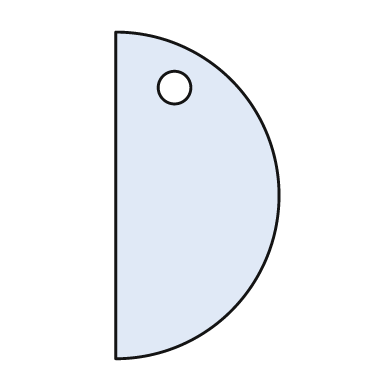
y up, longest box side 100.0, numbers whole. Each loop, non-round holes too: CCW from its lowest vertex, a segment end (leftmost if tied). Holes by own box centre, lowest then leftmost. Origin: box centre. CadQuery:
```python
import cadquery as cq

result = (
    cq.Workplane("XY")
    .moveTo(-25.0, -50.0)
    .threePointArc((25.0, 0.0), (-25.0, 50.0))
    .close()
    .moveTo(-7.0, 33.0)
    .circle(5.0)
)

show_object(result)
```